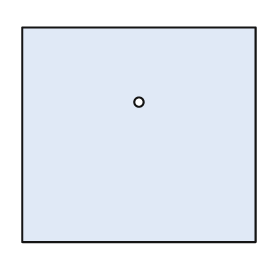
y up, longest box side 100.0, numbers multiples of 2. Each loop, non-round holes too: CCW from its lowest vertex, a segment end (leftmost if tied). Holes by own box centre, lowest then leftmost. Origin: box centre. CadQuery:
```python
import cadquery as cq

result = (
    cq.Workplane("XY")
    .moveTo(-50.0, -46.0)
    .lineTo(50.0, -46.0)
    .lineTo(50.0, 46.0)
    .lineTo(-50.0, 46.0)
    .close()
    .moveTo(0.0, 14.0)
    .circle(2.0)
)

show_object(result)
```